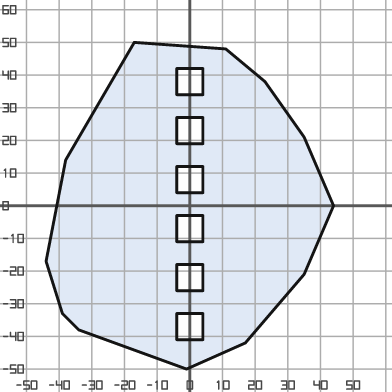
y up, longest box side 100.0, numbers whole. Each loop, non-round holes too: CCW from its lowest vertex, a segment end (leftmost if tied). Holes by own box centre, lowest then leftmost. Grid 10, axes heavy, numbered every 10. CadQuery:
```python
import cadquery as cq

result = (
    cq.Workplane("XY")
    .moveTo(-1.0, -50.0)
    .lineTo(17.0, -42.0)
    .lineTo(35.0, -21.0)
    .lineTo(44.0, 0.0)
    .lineTo(35.0, 21.0)
    .lineTo(23.0, 38.0)
    .lineTo(11.0, 48.0)
    .lineTo(-17.0, 50.0)
    .lineTo(-38.0, 14.0)
    .lineTo(-44.0, -17.0)
    .lineTo(-39.0, -33.0)
    .lineTo(-34.0, -38.0)
    .close()
    .moveTo(-4.0, -41.0)
    .lineTo(4.0, -41.0)
    .lineTo(4.0, -33.0)
    .lineTo(-4.0, -33.0)
    .close()
    .moveTo(-4.0, -26.0)
    .lineTo(4.0, -26.0)
    .lineTo(4.0, -18.0)
    .lineTo(-4.0, -18.0)
    .close()
    .moveTo(-4.0, -11.0)
    .lineTo(4.0, -11.0)
    .lineTo(4.0, -3.0)
    .lineTo(-4.0, -3.0)
    .close()
    .moveTo(-4.0, 4.0)
    .lineTo(4.0, 4.0)
    .lineTo(4.0, 12.0)
    .lineTo(-4.0, 12.0)
    .close()
    .moveTo(-4.0, 19.0)
    .lineTo(4.0, 19.0)
    .lineTo(4.0, 27.0)
    .lineTo(-4.0, 27.0)
    .close()
    .moveTo(-4.0, 34.0)
    .lineTo(4.0, 34.0)
    .lineTo(4.0, 42.0)
    .lineTo(-4.0, 42.0)
    .close()
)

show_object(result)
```